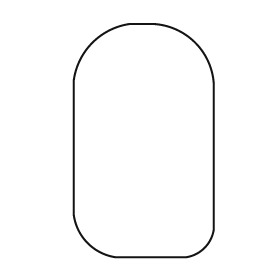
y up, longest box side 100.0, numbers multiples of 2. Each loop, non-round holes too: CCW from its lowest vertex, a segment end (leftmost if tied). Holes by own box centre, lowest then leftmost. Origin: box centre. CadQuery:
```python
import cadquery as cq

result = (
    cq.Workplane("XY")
    .moveTo(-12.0, -50.0)
    .lineTo(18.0, -50.0)
    .threePointArc((26.0, -46.0), (30.0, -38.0))
    .lineTo(30.0, 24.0)
    .threePointArc((22.0, 42.0), (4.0, 50.0))
    .lineTo(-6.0, 50.0)
    .threePointArc((-22.0, 42.0), (-30.0, 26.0))
    .lineTo(-30.0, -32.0)
    .threePointArc((-24.0, -44.0), (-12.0, -50.0))
    .close()
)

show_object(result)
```